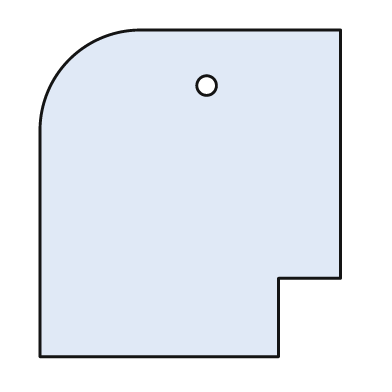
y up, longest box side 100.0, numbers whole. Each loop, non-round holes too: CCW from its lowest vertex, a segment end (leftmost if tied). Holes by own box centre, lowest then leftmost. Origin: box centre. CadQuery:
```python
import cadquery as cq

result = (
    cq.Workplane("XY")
    .moveTo(-46.0, -50.0)
    .lineTo(27.0, -50.0)
    .lineTo(27.0, -26.0)
    .lineTo(46.0, -26.0)
    .lineTo(46.0, 50.0)
    .lineTo(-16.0, 50.0)
    .threePointArc((-37.0, 41.0), (-46.0, 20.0))
    .close()
    .moveTo(5.0, 33.0)
    .circle(3.0)
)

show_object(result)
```